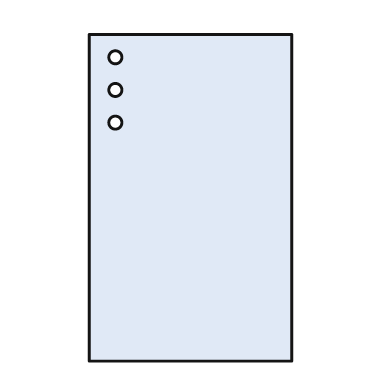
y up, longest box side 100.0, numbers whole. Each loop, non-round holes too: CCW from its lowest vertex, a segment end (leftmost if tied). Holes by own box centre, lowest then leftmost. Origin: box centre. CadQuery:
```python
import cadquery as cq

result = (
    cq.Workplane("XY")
    .moveTo(-31.0, -50.0)
    .lineTo(31.0, -50.0)
    .lineTo(31.0, 50.0)
    .lineTo(-31.0, 50.0)
    .close()
    .moveTo(-23.0, 23.0)
    .circle(2.0)
    .moveTo(-23.0, 33.0)
    .circle(2.0)
    .moveTo(-23.0, 43.0)
    .circle(2.0)
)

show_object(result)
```